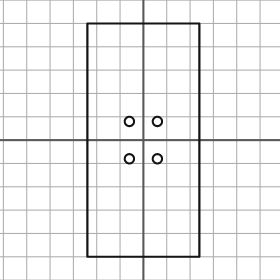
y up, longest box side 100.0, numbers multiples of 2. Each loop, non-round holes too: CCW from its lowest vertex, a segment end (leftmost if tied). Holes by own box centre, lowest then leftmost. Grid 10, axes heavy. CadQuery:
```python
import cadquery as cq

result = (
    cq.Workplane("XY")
    .moveTo(-24.0, -50.0)
    .lineTo(24.0, -50.0)
    .lineTo(24.0, 50.0)
    .lineTo(-24.0, 50.0)
    .close()
    .moveTo(-6.0, -8.0)
    .circle(2.0)
    .moveTo(6.0, -8.0)
    .circle(2.0)
    .moveTo(-6.0, 8.0)
    .circle(2.0)
    .moveTo(6.0, 8.0)
    .circle(2.0)
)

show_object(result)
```